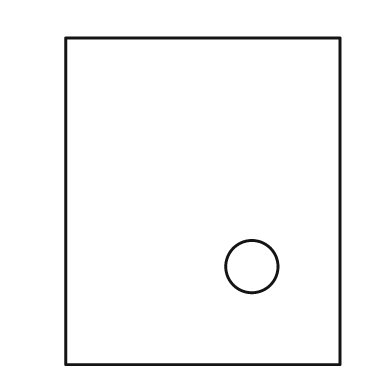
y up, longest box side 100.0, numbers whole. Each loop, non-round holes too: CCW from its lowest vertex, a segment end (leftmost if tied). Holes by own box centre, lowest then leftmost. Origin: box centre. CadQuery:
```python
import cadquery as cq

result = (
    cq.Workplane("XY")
    .moveTo(-42.0, -50.0)
    .lineTo(42.0, -50.0)
    .lineTo(42.0, 50.0)
    .lineTo(-42.0, 50.0)
    .close()
    .moveTo(15.0, -20.0)
    .circle(8.0)
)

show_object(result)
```